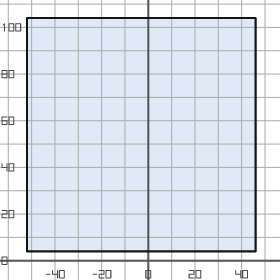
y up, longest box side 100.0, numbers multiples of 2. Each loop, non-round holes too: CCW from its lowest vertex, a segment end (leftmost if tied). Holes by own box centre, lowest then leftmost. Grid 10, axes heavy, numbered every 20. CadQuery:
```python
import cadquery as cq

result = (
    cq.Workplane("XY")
    .moveTo(-52.0, 4.0)
    .lineTo(46.0, 4.0)
    .lineTo(46.0, 104.0)
    .lineTo(-52.0, 104.0)
    .close()
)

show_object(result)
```